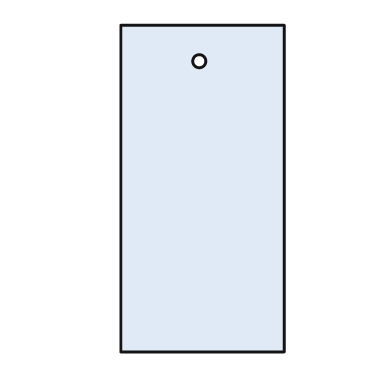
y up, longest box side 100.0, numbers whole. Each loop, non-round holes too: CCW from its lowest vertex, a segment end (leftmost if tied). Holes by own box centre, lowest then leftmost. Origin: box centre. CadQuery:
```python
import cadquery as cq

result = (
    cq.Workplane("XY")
    .moveTo(-25.0, -50.0)
    .lineTo(25.0, -50.0)
    .lineTo(25.0, 50.0)
    .lineTo(-25.0, 50.0)
    .close()
    .moveTo(-1.0, 39.0)
    .circle(2.0)
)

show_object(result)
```